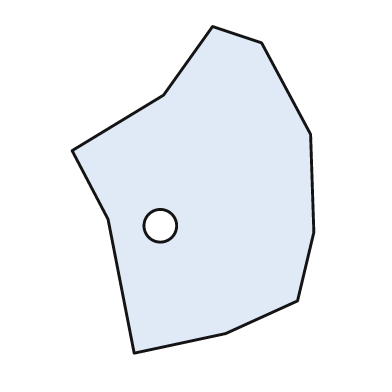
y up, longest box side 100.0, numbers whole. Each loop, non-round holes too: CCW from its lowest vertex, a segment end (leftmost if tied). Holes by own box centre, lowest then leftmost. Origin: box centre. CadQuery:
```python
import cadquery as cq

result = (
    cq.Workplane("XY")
    .moveTo(-18.0, -50.0)
    .lineTo(10.0, -44.0)
    .lineTo(32.0, -34.0)
    .lineTo(37.0, -13.0)
    .lineTo(36.0, 17.0)
    .lineTo(21.0, 45.0)
    .lineTo(6.0, 50.0)
    .lineTo(-9.0, 29.0)
    .lineTo(-37.0, 12.0)
    .lineTo(-26.0, -9.0)
    .close()
    .moveTo(-10.0, -11.0)
    .circle(5.0)
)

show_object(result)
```